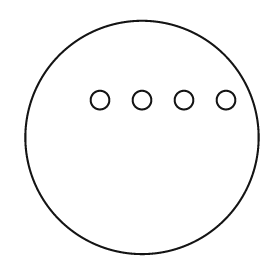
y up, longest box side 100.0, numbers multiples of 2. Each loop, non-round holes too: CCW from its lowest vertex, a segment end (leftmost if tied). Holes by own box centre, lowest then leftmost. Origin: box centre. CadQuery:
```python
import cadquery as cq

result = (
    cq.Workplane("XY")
    .moveTo(0.0, 0.0)
    .circle(50.0)
    .moveTo(-18.0, 16.0)
    .circle(4.0)
    .moveTo(0.0, 16.0)
    .circle(4.0)
    .moveTo(18.0, 16.0)
    .circle(4.0)
    .moveTo(36.0, 16.0)
    .circle(4.0)
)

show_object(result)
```